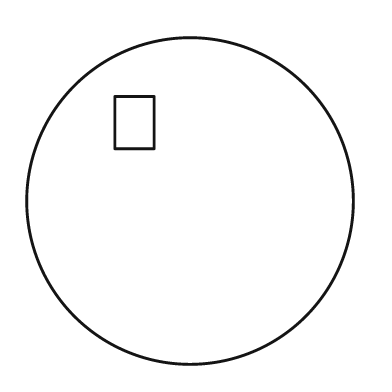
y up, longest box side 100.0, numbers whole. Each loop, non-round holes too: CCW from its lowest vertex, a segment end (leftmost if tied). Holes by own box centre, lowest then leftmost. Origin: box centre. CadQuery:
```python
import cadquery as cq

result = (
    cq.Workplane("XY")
    .moveTo(0.0, 0.0)
    .circle(50.0)
    .moveTo(-23.0, 16.0)
    .lineTo(-11.0, 16.0)
    .lineTo(-11.0, 32.0)
    .lineTo(-23.0, 32.0)
    .close()
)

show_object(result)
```